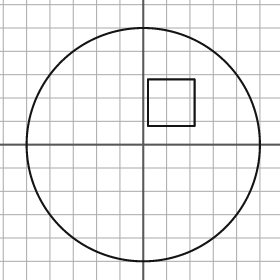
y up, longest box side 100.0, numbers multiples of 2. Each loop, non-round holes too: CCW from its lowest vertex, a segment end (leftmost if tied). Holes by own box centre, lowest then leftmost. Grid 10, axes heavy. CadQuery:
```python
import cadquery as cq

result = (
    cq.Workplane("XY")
    .moveTo(0.0, 0.0)
    .circle(50.0)
    .moveTo(2.0, 8.0)
    .lineTo(22.0, 8.0)
    .lineTo(22.0, 28.0)
    .lineTo(2.0, 28.0)
    .close()
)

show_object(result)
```